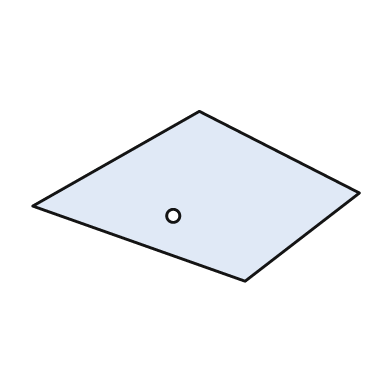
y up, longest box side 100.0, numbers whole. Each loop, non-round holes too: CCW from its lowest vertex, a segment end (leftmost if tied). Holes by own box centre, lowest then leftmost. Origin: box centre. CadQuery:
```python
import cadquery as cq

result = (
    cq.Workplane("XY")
    .moveTo(15.0, -26.0)
    .lineTo(50.0, 1.0)
    .lineTo(1.0, 26.0)
    .lineTo(-50.0, -3.0)
    .close()
    .moveTo(-7.0, -6.0)
    .circle(2.0)
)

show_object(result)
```